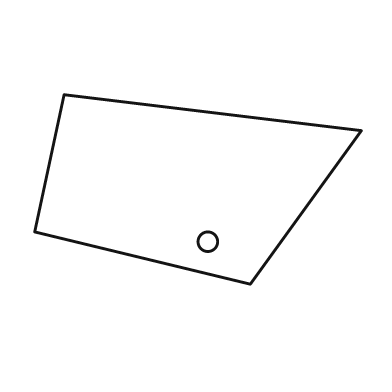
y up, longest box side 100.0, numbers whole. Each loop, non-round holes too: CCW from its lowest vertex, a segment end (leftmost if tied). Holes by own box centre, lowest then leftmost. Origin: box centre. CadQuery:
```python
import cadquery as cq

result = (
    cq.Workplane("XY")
    .moveTo(16.0, -29.0)
    .lineTo(50.0, 18.0)
    .lineTo(-41.0, 29.0)
    .lineTo(-50.0, -13.0)
    .close()
    .moveTo(3.0, -16.0)
    .circle(3.0)
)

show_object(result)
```